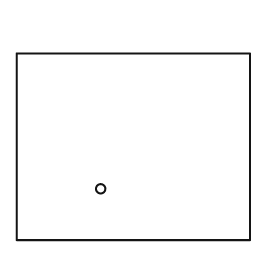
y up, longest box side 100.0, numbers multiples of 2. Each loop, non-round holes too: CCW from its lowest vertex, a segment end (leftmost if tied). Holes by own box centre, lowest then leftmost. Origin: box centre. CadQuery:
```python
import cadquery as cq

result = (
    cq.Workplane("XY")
    .moveTo(-50.0, -40.0)
    .lineTo(50.0, -40.0)
    .lineTo(50.0, 40.0)
    .lineTo(-50.0, 40.0)
    .close()
    .moveTo(-14.0, -18.0)
    .circle(2.0)
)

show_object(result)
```